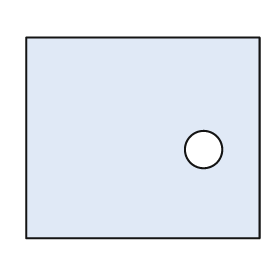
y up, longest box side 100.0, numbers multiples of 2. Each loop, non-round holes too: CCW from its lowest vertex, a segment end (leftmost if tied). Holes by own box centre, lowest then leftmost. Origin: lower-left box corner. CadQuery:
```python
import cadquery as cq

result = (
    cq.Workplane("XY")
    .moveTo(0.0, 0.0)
    .lineTo(100.0, 0.0)
    .lineTo(100.0, 86.0)
    .lineTo(0.0, 86.0)
    .close()
    .moveTo(76.0, 38.0)
    .circle(8.0)
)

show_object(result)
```